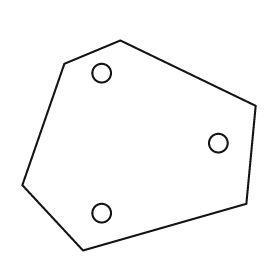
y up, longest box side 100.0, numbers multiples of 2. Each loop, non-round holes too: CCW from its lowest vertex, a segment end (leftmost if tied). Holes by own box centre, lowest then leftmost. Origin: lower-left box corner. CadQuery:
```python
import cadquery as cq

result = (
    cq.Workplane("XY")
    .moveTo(26.0, 0.0)
    .lineTo(96.0, 20.0)
    .lineTo(100.0, 62.0)
    .lineTo(42.0, 90.0)
    .lineTo(18.0, 80.0)
    .lineTo(0.0, 28.0)
    .close()
    .moveTo(34.0, 16.0)
    .circle(4.0)
    .moveTo(84.0, 46.0)
    .circle(4.0)
    .moveTo(34.0, 76.0)
    .circle(4.0)
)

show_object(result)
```